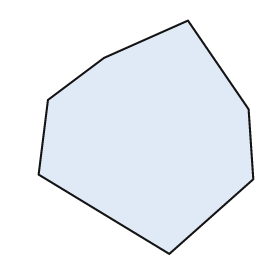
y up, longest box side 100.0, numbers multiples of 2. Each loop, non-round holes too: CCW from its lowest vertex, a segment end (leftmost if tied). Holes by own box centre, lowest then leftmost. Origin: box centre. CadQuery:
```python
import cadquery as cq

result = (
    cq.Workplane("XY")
    .moveTo(10.0, -50.0)
    .lineTo(46.0, -18.0)
    .lineTo(44.0, 12.0)
    .lineTo(18.0, 50.0)
    .lineTo(-18.0, 34.0)
    .lineTo(-42.0, 16.0)
    .lineTo(-46.0, -16.0)
    .close()
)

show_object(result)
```